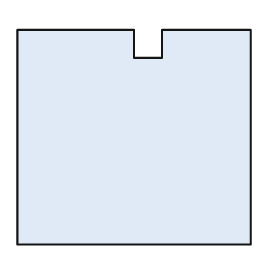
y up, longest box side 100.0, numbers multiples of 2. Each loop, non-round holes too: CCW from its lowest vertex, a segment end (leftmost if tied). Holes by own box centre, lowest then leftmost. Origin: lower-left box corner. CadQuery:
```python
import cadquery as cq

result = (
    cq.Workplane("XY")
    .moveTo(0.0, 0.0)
    .lineTo(100.0, 0.0)
    .lineTo(100.0, 92.0)
    .lineTo(62.0, 92.0)
    .lineTo(62.0, 80.0)
    .lineTo(50.0, 80.0)
    .lineTo(50.0, 92.0)
    .lineTo(0.0, 92.0)
    .close()
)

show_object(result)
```